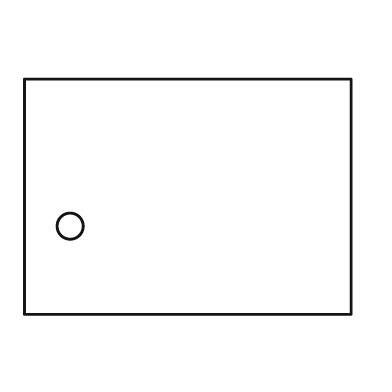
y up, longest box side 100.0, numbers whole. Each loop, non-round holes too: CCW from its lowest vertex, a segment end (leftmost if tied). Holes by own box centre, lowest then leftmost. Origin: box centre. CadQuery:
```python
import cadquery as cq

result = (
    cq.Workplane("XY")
    .moveTo(-50.0, -36.0)
    .lineTo(50.0, -36.0)
    .lineTo(50.0, 36.0)
    .lineTo(-50.0, 36.0)
    .close()
    .moveTo(-36.0, -9.0)
    .circle(4.0)
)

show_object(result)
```